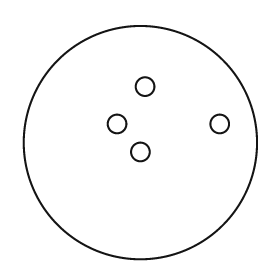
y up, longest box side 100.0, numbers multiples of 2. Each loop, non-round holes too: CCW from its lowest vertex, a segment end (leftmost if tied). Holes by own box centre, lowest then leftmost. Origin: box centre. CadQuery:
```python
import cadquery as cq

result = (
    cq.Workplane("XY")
    .moveTo(0.0, 0.0)
    .circle(50.0)
    .moveTo(0.0, -4.0)
    .circle(4.0)
    .moveTo(-10.0, 8.0)
    .circle(4.0)
    .moveTo(34.0, 8.0)
    .circle(4.0)
    .moveTo(2.0, 24.0)
    .circle(4.0)
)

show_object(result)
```